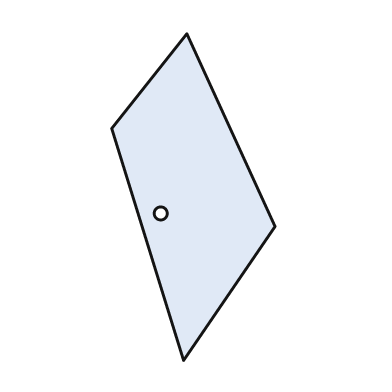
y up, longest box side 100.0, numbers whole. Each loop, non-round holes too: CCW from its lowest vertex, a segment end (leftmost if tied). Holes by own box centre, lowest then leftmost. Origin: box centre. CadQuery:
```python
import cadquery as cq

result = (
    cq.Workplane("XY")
    .moveTo(-3.0, -50.0)
    .lineTo(25.0, -9.0)
    .lineTo(-2.0, 50.0)
    .lineTo(-25.0, 21.0)
    .close()
    .moveTo(-10.0, -5.0)
    .circle(2.0)
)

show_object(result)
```